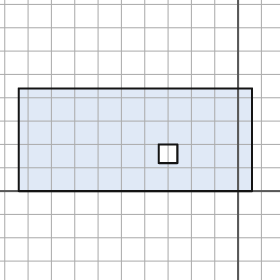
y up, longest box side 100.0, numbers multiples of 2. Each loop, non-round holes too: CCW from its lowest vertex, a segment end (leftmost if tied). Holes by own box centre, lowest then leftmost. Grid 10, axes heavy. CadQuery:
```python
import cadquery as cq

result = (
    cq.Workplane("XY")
    .moveTo(-94.0, 0.0)
    .lineTo(6.0, 0.0)
    .lineTo(6.0, 44.0)
    .lineTo(-94.0, 44.0)
    .close()
    .moveTo(-34.0, 12.0)
    .lineTo(-26.0, 12.0)
    .lineTo(-26.0, 20.0)
    .lineTo(-34.0, 20.0)
    .close()
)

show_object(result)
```